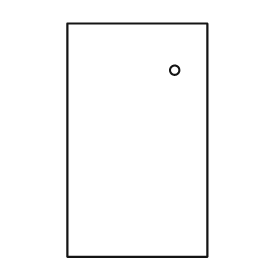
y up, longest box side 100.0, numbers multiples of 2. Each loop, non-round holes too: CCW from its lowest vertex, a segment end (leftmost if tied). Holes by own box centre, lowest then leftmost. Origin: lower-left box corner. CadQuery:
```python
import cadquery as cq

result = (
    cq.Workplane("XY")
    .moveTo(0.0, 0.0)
    .lineTo(60.0, 0.0)
    .lineTo(60.0, 100.0)
    .lineTo(0.0, 100.0)
    .close()
    .moveTo(46.0, 80.0)
    .circle(2.0)
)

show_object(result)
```